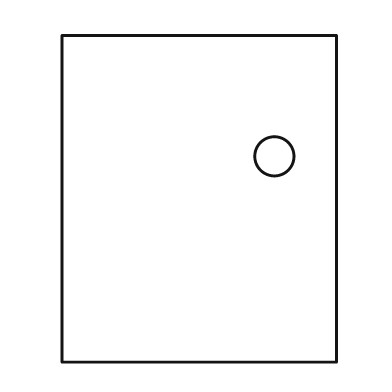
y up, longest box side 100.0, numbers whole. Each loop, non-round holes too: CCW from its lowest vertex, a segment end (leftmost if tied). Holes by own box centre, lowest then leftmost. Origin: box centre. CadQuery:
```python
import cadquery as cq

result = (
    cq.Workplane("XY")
    .moveTo(-42.0, -50.0)
    .lineTo(42.0, -50.0)
    .lineTo(42.0, 50.0)
    .lineTo(-42.0, 50.0)
    .close()
    .moveTo(23.0, 13.0)
    .circle(6.0)
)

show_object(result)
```